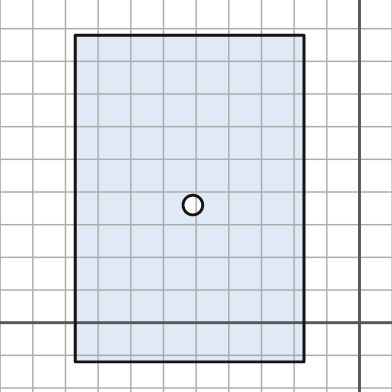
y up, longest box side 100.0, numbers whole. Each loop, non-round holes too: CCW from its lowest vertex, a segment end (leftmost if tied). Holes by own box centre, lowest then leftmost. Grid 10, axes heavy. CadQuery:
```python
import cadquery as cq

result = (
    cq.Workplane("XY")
    .moveTo(-87.0, -12.0)
    .lineTo(-17.0, -12.0)
    .lineTo(-17.0, 88.0)
    .lineTo(-87.0, 88.0)
    .close()
    .moveTo(-51.0, 36.0)
    .circle(3.0)
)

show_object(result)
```